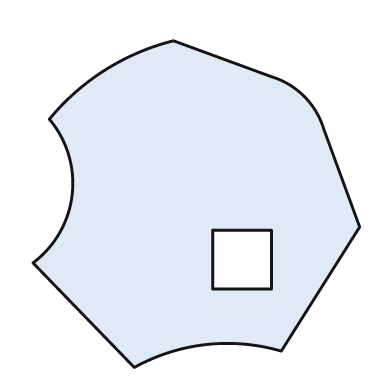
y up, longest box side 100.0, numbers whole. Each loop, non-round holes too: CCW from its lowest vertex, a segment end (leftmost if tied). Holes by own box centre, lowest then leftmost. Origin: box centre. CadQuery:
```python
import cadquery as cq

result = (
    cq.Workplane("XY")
    .moveTo(-19.0, -50.0)
    .threePointArc((3.0, -43.0), (26.0, -45.0))
    .lineTo(50.0, -7.0)
    .lineTo(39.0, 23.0)
    .threePointArc((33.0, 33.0), (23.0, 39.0))
    .lineTo(-7.0, 50.0)
    .threePointArc((-28.0, 41.0), (-45.0, 26.0))
    .threePointArc((-38.0, 3.0), (-50.0, -18.0))
    .close()
    .moveTo(5.0, -26.0)
    .lineTo(23.0, -26.0)
    .lineTo(23.0, -8.0)
    .lineTo(5.0, -8.0)
    .close()
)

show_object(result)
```